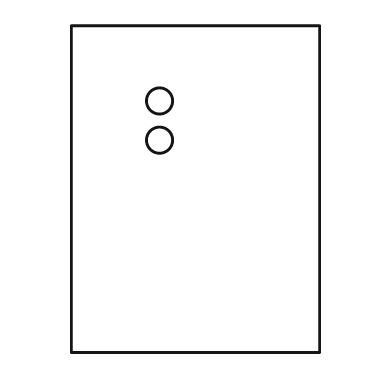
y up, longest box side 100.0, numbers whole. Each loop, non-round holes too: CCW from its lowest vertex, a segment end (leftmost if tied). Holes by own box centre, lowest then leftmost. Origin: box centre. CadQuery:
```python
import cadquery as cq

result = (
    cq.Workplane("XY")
    .moveTo(-38.0, -50.0)
    .lineTo(38.0, -50.0)
    .lineTo(38.0, 50.0)
    .lineTo(-38.0, 50.0)
    .close()
    .moveTo(-11.0, 15.0)
    .circle(4.0)
    .moveTo(-11.0, 27.0)
    .circle(4.0)
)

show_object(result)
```